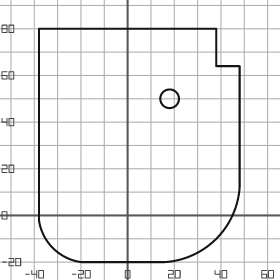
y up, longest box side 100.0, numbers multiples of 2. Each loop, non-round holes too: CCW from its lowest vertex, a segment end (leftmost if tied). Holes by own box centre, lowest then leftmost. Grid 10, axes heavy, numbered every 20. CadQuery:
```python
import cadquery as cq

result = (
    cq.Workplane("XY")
    .moveTo(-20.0, -20.0)
    .lineTo(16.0, -20.0)
    .threePointArc((38.0, -10.0), (48.0, 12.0))
    .lineTo(48.0, 64.0)
    .lineTo(38.0, 64.0)
    .lineTo(38.0, 80.0)
    .lineTo(-38.0, 80.0)
    .lineTo(-38.0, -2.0)
    .threePointArc((-32.0, -14.0), (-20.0, -20.0))
    .close()
    .moveTo(18.0, 50.0)
    .circle(4.0)
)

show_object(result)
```